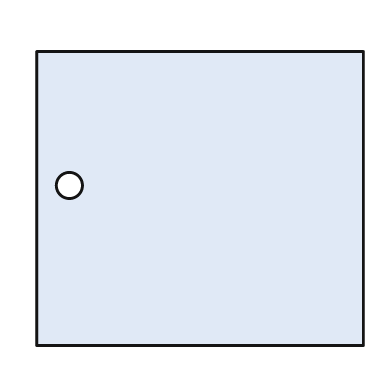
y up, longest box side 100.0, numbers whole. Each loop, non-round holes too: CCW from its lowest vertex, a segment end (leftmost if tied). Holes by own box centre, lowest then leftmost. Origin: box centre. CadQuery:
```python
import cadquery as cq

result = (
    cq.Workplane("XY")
    .moveTo(-50.0, -45.0)
    .lineTo(50.0, -45.0)
    .lineTo(50.0, 45.0)
    .lineTo(-50.0, 45.0)
    .close()
    .moveTo(-40.0, 4.0)
    .circle(4.0)
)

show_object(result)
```